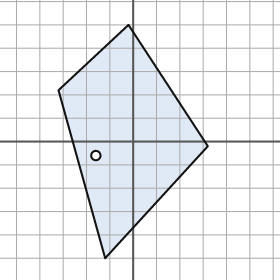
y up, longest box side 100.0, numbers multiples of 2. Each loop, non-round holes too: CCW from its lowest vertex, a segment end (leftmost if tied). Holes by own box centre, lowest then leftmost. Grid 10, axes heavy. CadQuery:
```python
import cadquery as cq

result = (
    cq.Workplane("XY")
    .moveTo(-12.0, -50.0)
    .lineTo(32.0, -2.0)
    .lineTo(-2.0, 50.0)
    .lineTo(-32.0, 22.0)
    .close()
    .moveTo(-16.0, -6.0)
    .circle(2.0)
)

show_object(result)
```